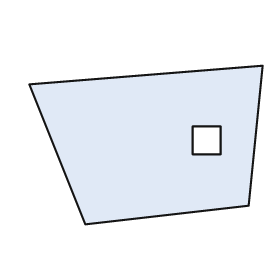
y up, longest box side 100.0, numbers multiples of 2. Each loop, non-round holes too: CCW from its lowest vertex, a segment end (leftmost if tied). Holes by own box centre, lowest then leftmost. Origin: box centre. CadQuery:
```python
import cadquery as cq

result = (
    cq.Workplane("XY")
    .moveTo(-26.0, -34.0)
    .lineTo(44.0, -26.0)
    .lineTo(50.0, 34.0)
    .lineTo(-50.0, 26.0)
    .close()
    .moveTo(20.0, -4.0)
    .lineTo(32.0, -4.0)
    .lineTo(32.0, 8.0)
    .lineTo(20.0, 8.0)
    .close()
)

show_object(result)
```